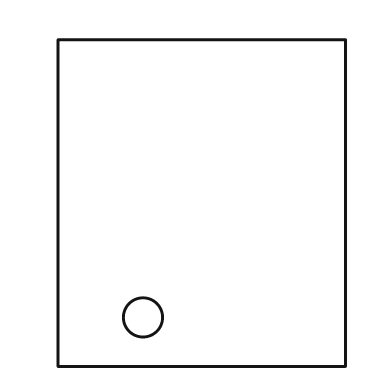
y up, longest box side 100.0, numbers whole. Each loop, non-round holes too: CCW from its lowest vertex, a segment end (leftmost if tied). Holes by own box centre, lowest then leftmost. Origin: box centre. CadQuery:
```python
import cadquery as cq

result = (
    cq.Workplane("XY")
    .moveTo(-44.0, -50.0)
    .lineTo(44.0, -50.0)
    .lineTo(44.0, 50.0)
    .lineTo(-44.0, 50.0)
    .close()
    .moveTo(-18.0, -35.0)
    .circle(6.0)
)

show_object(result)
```